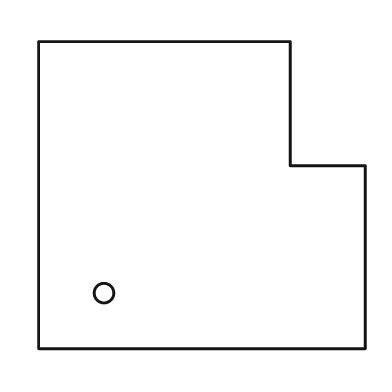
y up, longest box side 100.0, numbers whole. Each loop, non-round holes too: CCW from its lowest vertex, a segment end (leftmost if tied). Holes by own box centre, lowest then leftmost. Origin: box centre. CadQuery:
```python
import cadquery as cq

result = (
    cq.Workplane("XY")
    .moveTo(-50.0, -47.0)
    .lineTo(50.0, -47.0)
    .lineTo(50.0, 9.0)
    .lineTo(27.0, 9.0)
    .lineTo(27.0, 47.0)
    .lineTo(-50.0, 47.0)
    .close()
    .moveTo(-30.0, -30.0)
    .circle(3.0)
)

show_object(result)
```